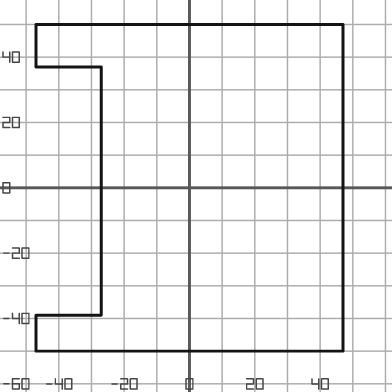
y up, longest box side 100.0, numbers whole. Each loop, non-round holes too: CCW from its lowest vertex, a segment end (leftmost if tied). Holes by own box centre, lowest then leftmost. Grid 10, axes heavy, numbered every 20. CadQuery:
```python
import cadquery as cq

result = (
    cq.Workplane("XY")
    .moveTo(-47.0, -50.0)
    .lineTo(47.0, -50.0)
    .lineTo(47.0, 50.0)
    .lineTo(-47.0, 50.0)
    .lineTo(-47.0, 37.0)
    .lineTo(-27.0, 37.0)
    .lineTo(-27.0, -39.0)
    .lineTo(-47.0, -39.0)
    .close()
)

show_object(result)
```